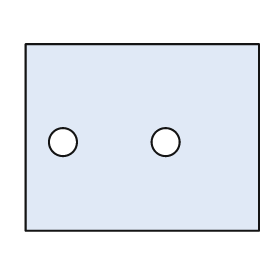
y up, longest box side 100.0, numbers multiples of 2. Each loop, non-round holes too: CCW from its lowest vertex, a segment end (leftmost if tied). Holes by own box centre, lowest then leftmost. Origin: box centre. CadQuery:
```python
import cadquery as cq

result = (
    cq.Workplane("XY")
    .moveTo(-50.0, -40.0)
    .lineTo(50.0, -40.0)
    .lineTo(50.0, 40.0)
    .lineTo(-50.0, 40.0)
    .close()
    .moveTo(-34.0, -2.0)
    .circle(6.0)
    .moveTo(10.0, -2.0)
    .circle(6.0)
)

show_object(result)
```